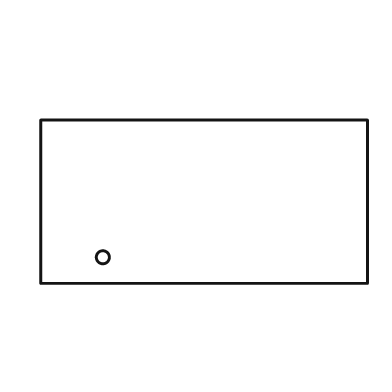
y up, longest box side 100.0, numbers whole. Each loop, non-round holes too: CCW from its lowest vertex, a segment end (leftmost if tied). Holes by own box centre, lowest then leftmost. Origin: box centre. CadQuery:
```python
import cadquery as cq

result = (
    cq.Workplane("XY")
    .moveTo(-50.0, -25.0)
    .lineTo(50.0, -25.0)
    .lineTo(50.0, 25.0)
    .lineTo(-50.0, 25.0)
    .close()
    .moveTo(-31.0, -17.0)
    .circle(2.0)
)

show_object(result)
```